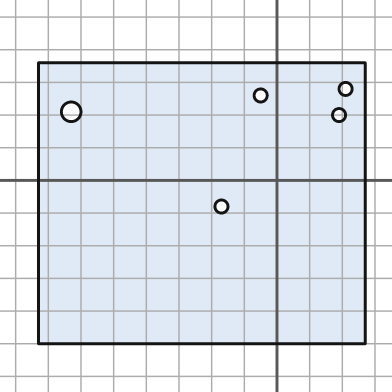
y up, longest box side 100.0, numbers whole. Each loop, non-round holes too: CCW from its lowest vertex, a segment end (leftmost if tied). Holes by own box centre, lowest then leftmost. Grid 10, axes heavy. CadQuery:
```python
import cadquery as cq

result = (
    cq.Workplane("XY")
    .moveTo(-73.0, -50.0)
    .lineTo(27.0, -50.0)
    .lineTo(27.0, 36.0)
    .lineTo(-73.0, 36.0)
    .close()
    .moveTo(-17.0, -8.0)
    .circle(2.0)
    .moveTo(19.0, 20.0)
    .circle(2.0)
    .moveTo(-63.0, 21.0)
    .circle(3.0)
    .moveTo(-5.0, 26.0)
    .circle(2.0)
    .moveTo(21.0, 28.0)
    .circle(2.0)
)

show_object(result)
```